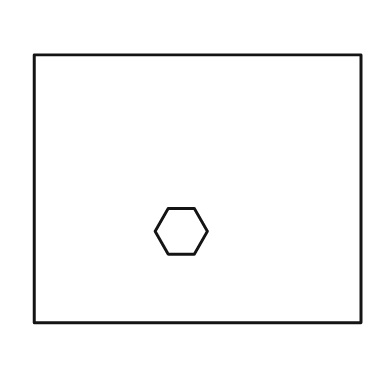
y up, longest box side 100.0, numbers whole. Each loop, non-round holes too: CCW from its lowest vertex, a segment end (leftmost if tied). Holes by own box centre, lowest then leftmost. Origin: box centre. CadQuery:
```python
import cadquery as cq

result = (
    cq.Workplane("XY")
    .moveTo(-50.0, -41.0)
    .lineTo(50.0, -41.0)
    .lineTo(50.0, 41.0)
    .lineTo(-50.0, 41.0)
    .close()
    .moveTo(-9.0, -20.0)
    .lineTo(-1.0, -20.0)
    .lineTo(3.0, -13.0)
    .lineTo(-1.0, -6.0)
    .lineTo(-9.0, -6.0)
    .lineTo(-13.0, -13.0)
    .close()
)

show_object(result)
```